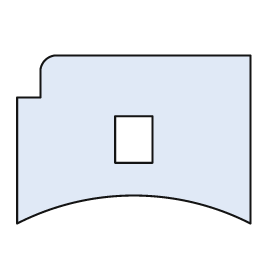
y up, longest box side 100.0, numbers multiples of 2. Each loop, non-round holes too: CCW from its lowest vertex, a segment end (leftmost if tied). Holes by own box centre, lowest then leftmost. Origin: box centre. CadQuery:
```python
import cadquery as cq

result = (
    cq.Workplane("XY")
    .moveTo(-50.0, -36.0)
    .threePointArc((0.0, -24.0), (50.0, -36.0))
    .lineTo(50.0, 36.0)
    .lineTo(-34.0, 36.0)
    .threePointArc((-38.0, 34.0), (-40.0, 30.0))
    .lineTo(-40.0, 18.0)
    .lineTo(-50.0, 18.0)
    .close()
    .moveTo(-8.0, -10.0)
    .lineTo(8.0, -10.0)
    .lineTo(8.0, 10.0)
    .lineTo(-8.0, 10.0)
    .close()
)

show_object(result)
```